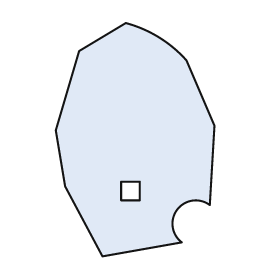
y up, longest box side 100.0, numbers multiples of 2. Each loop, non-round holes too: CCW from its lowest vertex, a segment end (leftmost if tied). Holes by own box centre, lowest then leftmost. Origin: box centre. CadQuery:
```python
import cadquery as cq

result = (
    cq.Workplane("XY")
    .moveTo(-14.0, -50.0)
    .lineTo(20.0, -44.0)
    .threePointArc((18.0, -30.0), (32.0, -28.0))
    .lineTo(34.0, 6.0)
    .lineTo(22.0, 34.0)
    .threePointArc((10.0, 44.0), (-4.0, 50.0))
    .lineTo(-24.0, 38.0)
    .lineTo(-34.0, 4.0)
    .lineTo(-30.0, -20.0)
    .close()
    .moveTo(-6.0, -26.0)
    .lineTo(2.0, -26.0)
    .lineTo(2.0, -18.0)
    .lineTo(-6.0, -18.0)
    .close()
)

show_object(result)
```